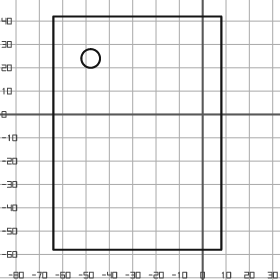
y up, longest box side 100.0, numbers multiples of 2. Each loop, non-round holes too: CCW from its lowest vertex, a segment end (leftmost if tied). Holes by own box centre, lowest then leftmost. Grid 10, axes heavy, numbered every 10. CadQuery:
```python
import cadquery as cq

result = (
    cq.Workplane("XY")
    .moveTo(-64.0, -58.0)
    .lineTo(8.0, -58.0)
    .lineTo(8.0, 42.0)
    .lineTo(-64.0, 42.0)
    .close()
    .moveTo(-48.0, 24.0)
    .circle(4.0)
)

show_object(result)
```